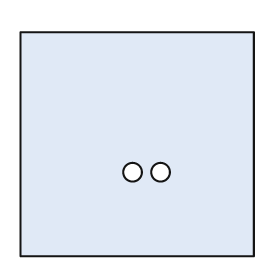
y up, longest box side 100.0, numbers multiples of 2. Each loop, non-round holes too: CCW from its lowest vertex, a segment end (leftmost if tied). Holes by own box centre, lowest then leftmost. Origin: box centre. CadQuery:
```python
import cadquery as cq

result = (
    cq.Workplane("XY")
    .moveTo(-50.0, -48.0)
    .lineTo(50.0, -48.0)
    .lineTo(50.0, 48.0)
    .lineTo(-50.0, 48.0)
    .close()
    .moveTo(-2.0, -12.0)
    .circle(4.0)
    .moveTo(10.0, -12.0)
    .circle(4.0)
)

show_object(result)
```